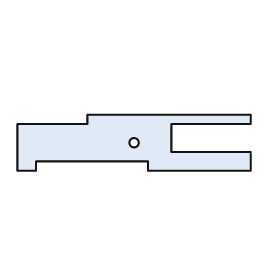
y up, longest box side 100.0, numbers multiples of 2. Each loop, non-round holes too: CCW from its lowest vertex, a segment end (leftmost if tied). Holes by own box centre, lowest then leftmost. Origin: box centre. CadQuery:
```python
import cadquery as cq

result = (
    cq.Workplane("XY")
    .moveTo(-50.0, -12.0)
    .lineTo(-42.0, -12.0)
    .lineTo(-42.0, -8.0)
    .lineTo(6.0, -8.0)
    .lineTo(6.0, -12.0)
    .lineTo(50.0, -12.0)
    .lineTo(50.0, -4.0)
    .lineTo(16.0, -4.0)
    .lineTo(16.0, 8.0)
    .lineTo(50.0, 8.0)
    .lineTo(50.0, 12.0)
    .lineTo(-20.0, 12.0)
    .lineTo(-20.0, 8.0)
    .lineTo(-50.0, 8.0)
    .close()
    .moveTo(0.0, 0.0)
    .circle(2.0)
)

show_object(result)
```